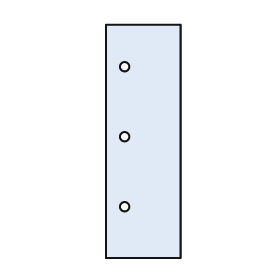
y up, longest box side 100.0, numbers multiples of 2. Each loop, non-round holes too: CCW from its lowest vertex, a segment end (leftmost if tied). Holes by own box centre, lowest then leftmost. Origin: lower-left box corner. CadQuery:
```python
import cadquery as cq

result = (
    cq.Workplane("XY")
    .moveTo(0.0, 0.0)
    .lineTo(32.0, 0.0)
    .lineTo(32.0, 100.0)
    .lineTo(0.0, 100.0)
    .close()
    .moveTo(8.0, 22.0)
    .circle(2.0)
    .moveTo(8.0, 52.0)
    .circle(2.0)
    .moveTo(8.0, 82.0)
    .circle(2.0)
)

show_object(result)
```